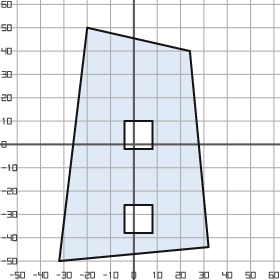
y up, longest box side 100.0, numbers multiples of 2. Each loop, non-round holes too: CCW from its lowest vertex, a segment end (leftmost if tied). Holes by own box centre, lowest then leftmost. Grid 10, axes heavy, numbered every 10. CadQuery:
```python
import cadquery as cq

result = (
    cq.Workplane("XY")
    .moveTo(-32.0, -50.0)
    .lineTo(32.0, -44.0)
    .lineTo(24.0, 40.0)
    .lineTo(-20.0, 50.0)
    .close()
    .moveTo(-4.0, -38.0)
    .lineTo(8.0, -38.0)
    .lineTo(8.0, -26.0)
    .lineTo(-4.0, -26.0)
    .close()
    .moveTo(-4.0, -2.0)
    .lineTo(8.0, -2.0)
    .lineTo(8.0, 10.0)
    .lineTo(-4.0, 10.0)
    .close()
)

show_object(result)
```